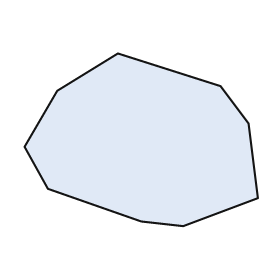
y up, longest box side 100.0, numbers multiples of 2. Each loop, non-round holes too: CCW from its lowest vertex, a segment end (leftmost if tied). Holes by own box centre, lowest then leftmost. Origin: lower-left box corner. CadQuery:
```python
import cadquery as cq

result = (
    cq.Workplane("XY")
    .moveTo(68.0, 0.0)
    .lineTo(100.0, 12.0)
    .lineTo(96.0, 44.0)
    .lineTo(84.0, 60.0)
    .lineTo(40.0, 74.0)
    .lineTo(14.0, 58.0)
    .lineTo(0.0, 34.0)
    .lineTo(10.0, 16.0)
    .lineTo(50.0, 2.0)
    .close()
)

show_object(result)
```